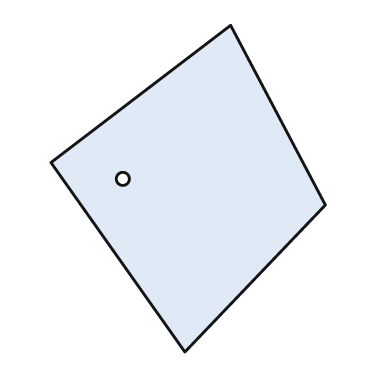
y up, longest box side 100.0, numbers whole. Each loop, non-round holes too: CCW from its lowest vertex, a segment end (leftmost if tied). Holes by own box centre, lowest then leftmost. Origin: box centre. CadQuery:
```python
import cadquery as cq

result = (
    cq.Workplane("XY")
    .moveTo(-1.0, -50.0)
    .lineTo(42.0, -5.0)
    .lineTo(13.0, 50.0)
    .lineTo(-42.0, 8.0)
    .close()
    .moveTo(-20.0, 3.0)
    .circle(2.0)
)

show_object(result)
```